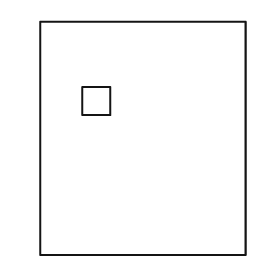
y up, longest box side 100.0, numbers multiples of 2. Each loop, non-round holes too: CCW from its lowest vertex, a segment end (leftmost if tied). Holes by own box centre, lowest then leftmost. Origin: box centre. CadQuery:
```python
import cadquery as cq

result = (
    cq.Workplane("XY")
    .moveTo(-44.0, -50.0)
    .lineTo(44.0, -50.0)
    .lineTo(44.0, 50.0)
    .lineTo(-44.0, 50.0)
    .close()
    .moveTo(-26.0, 10.0)
    .lineTo(-14.0, 10.0)
    .lineTo(-14.0, 22.0)
    .lineTo(-26.0, 22.0)
    .close()
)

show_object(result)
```